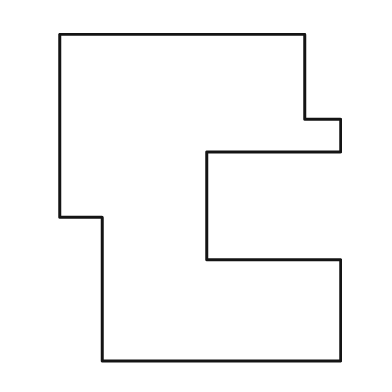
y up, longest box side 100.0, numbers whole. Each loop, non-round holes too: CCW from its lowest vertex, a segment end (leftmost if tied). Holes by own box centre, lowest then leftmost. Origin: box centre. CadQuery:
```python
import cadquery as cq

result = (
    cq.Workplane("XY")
    .moveTo(-30.0, -50.0)
    .lineTo(43.0, -50.0)
    .lineTo(43.0, -19.0)
    .lineTo(2.0, -19.0)
    .lineTo(2.0, 14.0)
    .lineTo(43.0, 14.0)
    .lineTo(43.0, 24.0)
    .lineTo(32.0, 24.0)
    .lineTo(32.0, 50.0)
    .lineTo(-43.0, 50.0)
    .lineTo(-43.0, -6.0)
    .lineTo(-30.0, -6.0)
    .close()
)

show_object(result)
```